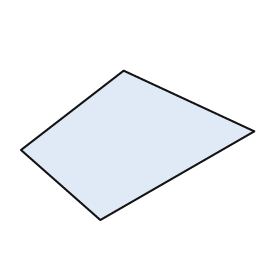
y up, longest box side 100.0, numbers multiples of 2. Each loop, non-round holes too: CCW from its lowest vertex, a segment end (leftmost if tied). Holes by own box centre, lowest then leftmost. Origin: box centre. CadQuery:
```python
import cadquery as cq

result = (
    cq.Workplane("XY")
    .moveTo(-16.0, -32.0)
    .lineTo(50.0, 6.0)
    .lineTo(-6.0, 32.0)
    .lineTo(-50.0, -2.0)
    .close()
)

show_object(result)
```